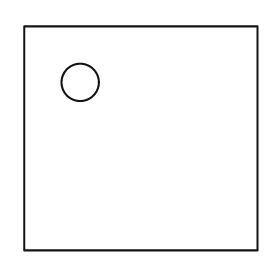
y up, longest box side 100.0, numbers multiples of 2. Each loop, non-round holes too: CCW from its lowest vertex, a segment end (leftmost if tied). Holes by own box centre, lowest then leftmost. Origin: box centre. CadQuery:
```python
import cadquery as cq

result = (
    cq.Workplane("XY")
    .moveTo(-50.0, -48.0)
    .lineTo(50.0, -48.0)
    .lineTo(50.0, 48.0)
    .lineTo(-50.0, 48.0)
    .close()
    .moveTo(-26.0, 24.0)
    .circle(8.0)
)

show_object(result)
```